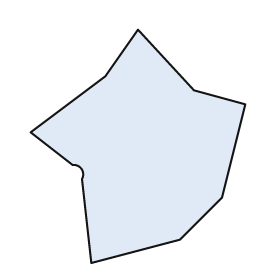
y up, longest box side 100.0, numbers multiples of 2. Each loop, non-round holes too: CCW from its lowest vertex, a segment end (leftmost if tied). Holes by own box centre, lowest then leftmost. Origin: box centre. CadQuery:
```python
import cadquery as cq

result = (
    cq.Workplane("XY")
    .moveTo(-20.0, -50.0)
    .lineTo(18.0, -40.0)
    .lineTo(36.0, -22.0)
    .lineTo(46.0, 18.0)
    .lineTo(24.0, 24.0)
    .lineTo(0.0, 50.0)
    .lineTo(-14.0, 30.0)
    .lineTo(-46.0, 6.0)
    .lineTo(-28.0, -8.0)
    .threePointArc((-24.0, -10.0), (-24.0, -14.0))
    .close()
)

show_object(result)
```